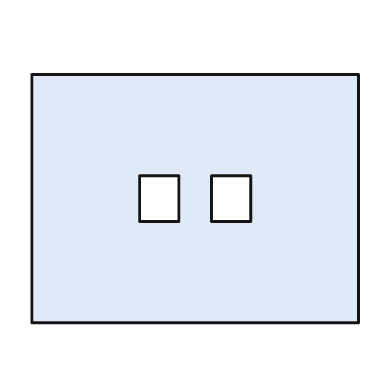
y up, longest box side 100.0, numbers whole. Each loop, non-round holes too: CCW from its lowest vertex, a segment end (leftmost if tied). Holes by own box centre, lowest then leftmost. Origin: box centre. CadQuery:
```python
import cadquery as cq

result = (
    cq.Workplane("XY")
    .moveTo(-50.0, -38.0)
    .lineTo(50.0, -38.0)
    .lineTo(50.0, 38.0)
    .lineTo(-50.0, 38.0)
    .close()
    .moveTo(-17.0, -7.0)
    .lineTo(-5.0, -7.0)
    .lineTo(-5.0, 7.0)
    .lineTo(-17.0, 7.0)
    .close()
    .moveTo(5.0, -7.0)
    .lineTo(17.0, -7.0)
    .lineTo(17.0, 7.0)
    .lineTo(5.0, 7.0)
    .close()
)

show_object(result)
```